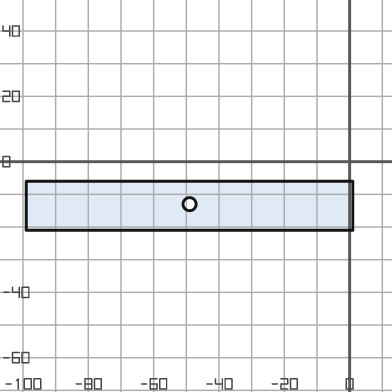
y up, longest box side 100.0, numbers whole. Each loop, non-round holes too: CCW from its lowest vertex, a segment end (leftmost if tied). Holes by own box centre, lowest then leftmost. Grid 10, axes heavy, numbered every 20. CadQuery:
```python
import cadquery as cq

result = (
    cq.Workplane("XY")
    .moveTo(-99.0, -21.0)
    .lineTo(1.0, -21.0)
    .lineTo(1.0, -6.0)
    .lineTo(-99.0, -6.0)
    .close()
    .moveTo(-49.0, -13.0)
    .circle(2.0)
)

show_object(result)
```